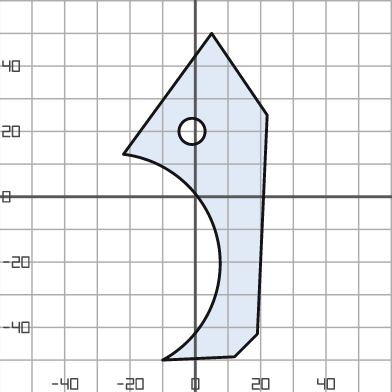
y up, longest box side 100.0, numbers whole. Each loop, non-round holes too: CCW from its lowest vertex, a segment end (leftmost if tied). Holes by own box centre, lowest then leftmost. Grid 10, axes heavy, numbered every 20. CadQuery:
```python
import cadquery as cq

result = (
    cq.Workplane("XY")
    .moveTo(-10.0, -50.0)
    .lineTo(12.0, -49.0)
    .lineTo(19.0, -42.0)
    .lineTo(22.0, 25.0)
    .lineTo(5.0, 50.0)
    .lineTo(-22.0, 13.0)
    .threePointArc((7.0, -14.0), (-10.0, -50.0))
    .close()
    .moveTo(-1.0, 20.0)
    .circle(4.0)
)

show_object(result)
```